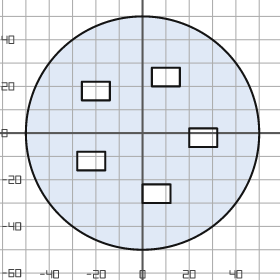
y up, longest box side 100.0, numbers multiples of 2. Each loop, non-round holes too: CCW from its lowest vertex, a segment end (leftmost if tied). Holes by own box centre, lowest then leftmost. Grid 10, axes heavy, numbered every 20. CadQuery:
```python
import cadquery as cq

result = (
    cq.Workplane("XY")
    .moveTo(0.0, 0.0)
    .circle(50.0)
    .moveTo(0.0, -30.0)
    .lineTo(12.0, -30.0)
    .lineTo(12.0, -22.0)
    .lineTo(0.0, -22.0)
    .close()
    .moveTo(-28.0, -16.0)
    .lineTo(-16.0, -16.0)
    .lineTo(-16.0, -8.0)
    .lineTo(-28.0, -8.0)
    .close()
    .moveTo(20.0, -6.0)
    .lineTo(32.0, -6.0)
    .lineTo(32.0, 2.0)
    .lineTo(20.0, 2.0)
    .close()
    .moveTo(-26.0, 14.0)
    .lineTo(-14.0, 14.0)
    .lineTo(-14.0, 22.0)
    .lineTo(-26.0, 22.0)
    .close()
    .moveTo(4.0, 20.0)
    .lineTo(16.0, 20.0)
    .lineTo(16.0, 28.0)
    .lineTo(4.0, 28.0)
    .close()
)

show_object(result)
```